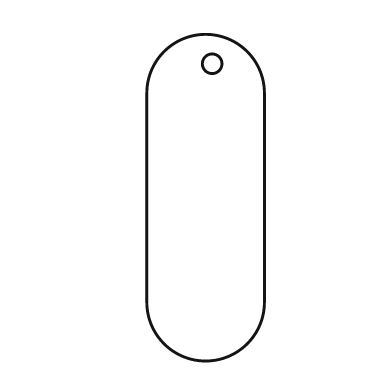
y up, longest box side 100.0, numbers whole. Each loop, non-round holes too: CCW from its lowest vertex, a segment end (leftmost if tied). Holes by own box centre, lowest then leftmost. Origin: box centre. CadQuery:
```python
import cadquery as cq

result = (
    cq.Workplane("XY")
    .moveTo(-18.0, -32.0)
    .threePointArc((0.0, -50.0), (18.0, -32.0))
    .lineTo(18.0, 32.0)
    .threePointArc((0.0, 50.0), (-18.0, 32.0))
    .close()
    .moveTo(2.0, 41.0)
    .circle(3.0)
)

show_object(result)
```